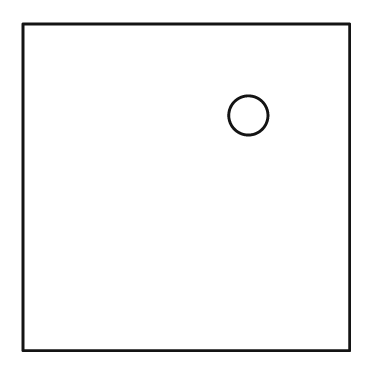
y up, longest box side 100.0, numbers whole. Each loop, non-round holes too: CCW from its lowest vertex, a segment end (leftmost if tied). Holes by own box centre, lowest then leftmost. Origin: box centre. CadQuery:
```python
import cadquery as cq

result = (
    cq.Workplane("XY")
    .moveTo(-50.0, -50.0)
    .lineTo(50.0, -50.0)
    .lineTo(50.0, 50.0)
    .lineTo(-50.0, 50.0)
    .close()
    .moveTo(19.0, 22.0)
    .circle(6.0)
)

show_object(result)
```